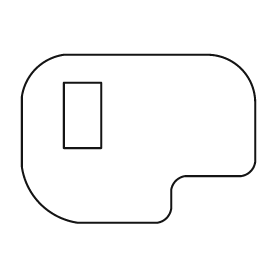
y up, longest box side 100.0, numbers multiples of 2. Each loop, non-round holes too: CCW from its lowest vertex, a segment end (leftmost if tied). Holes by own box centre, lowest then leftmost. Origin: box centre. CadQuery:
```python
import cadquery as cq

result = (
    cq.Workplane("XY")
    .moveTo(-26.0, -36.0)
    .lineTo(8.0, -36.0)
    .threePointArc((12.0, -34.0), (14.0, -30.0))
    .lineTo(14.0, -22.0)
    .threePointArc((16.0, -18.0), (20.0, -16.0))
    .lineTo(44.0, -16.0)
    .threePointArc((48.0, -14.0), (50.0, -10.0))
    .lineTo(50.0, 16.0)
    .threePointArc((44.0, 30.0), (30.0, 36.0))
    .lineTo(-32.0, 36.0)
    .threePointArc((-44.0, 30.0), (-50.0, 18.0))
    .lineTo(-50.0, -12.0)
    .threePointArc((-42.0, -28.0), (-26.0, -36.0))
    .close()
    .moveTo(-32.0, -4.0)
    .lineTo(-16.0, -4.0)
    .lineTo(-16.0, 24.0)
    .lineTo(-32.0, 24.0)
    .close()
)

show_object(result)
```